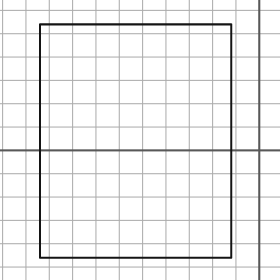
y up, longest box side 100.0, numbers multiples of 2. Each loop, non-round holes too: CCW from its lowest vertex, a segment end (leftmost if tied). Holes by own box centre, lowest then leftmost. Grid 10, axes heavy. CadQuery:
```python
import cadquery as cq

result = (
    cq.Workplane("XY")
    .moveTo(-94.0, -46.0)
    .lineTo(-12.0, -46.0)
    .lineTo(-12.0, 54.0)
    .lineTo(-94.0, 54.0)
    .close()
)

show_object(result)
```